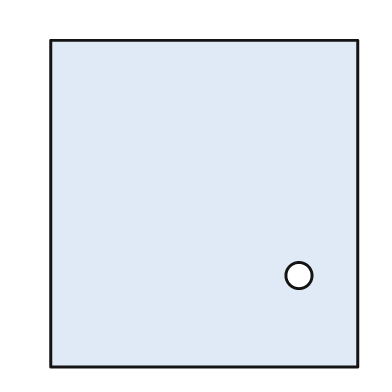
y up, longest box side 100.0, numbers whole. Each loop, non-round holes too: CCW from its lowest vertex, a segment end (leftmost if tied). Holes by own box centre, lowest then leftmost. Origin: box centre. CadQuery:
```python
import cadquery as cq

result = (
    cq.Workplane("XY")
    .moveTo(-47.0, -50.0)
    .lineTo(47.0, -50.0)
    .lineTo(47.0, 50.0)
    .lineTo(-47.0, 50.0)
    .close()
    .moveTo(29.0, -22.0)
    .circle(4.0)
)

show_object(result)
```